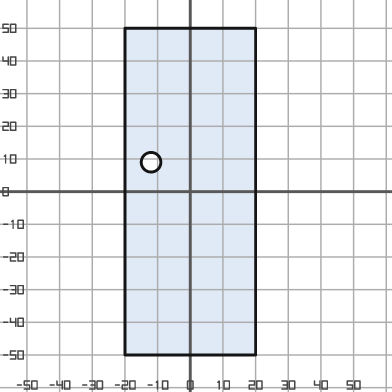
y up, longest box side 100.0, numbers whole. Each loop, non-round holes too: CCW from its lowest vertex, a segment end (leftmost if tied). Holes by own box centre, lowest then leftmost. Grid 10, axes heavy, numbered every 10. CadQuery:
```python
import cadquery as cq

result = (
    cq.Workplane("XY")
    .moveTo(-20.0, -50.0)
    .lineTo(20.0, -50.0)
    .lineTo(20.0, 50.0)
    .lineTo(-20.0, 50.0)
    .close()
    .moveTo(-12.0, 9.0)
    .circle(3.0)
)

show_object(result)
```